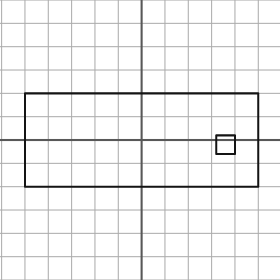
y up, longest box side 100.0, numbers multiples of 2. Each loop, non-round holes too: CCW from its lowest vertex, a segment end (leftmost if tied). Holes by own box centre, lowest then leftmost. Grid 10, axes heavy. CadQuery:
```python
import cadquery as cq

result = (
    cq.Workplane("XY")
    .moveTo(-50.0, -20.0)
    .lineTo(50.0, -20.0)
    .lineTo(50.0, 20.0)
    .lineTo(-50.0, 20.0)
    .close()
    .moveTo(32.0, -6.0)
    .lineTo(40.0, -6.0)
    .lineTo(40.0, 2.0)
    .lineTo(32.0, 2.0)
    .close()
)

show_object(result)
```